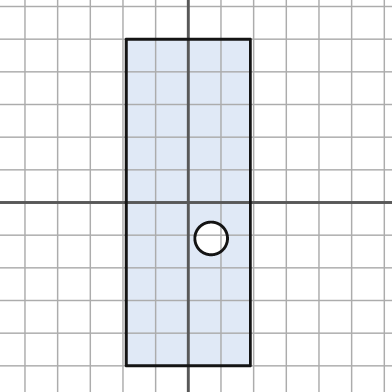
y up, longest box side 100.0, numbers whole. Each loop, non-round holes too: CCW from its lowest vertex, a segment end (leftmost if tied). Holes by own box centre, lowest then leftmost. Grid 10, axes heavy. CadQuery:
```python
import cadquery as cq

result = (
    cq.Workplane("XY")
    .moveTo(-19.0, -50.0)
    .lineTo(19.0, -50.0)
    .lineTo(19.0, 50.0)
    .lineTo(-19.0, 50.0)
    .close()
    .moveTo(7.0, -11.0)
    .circle(5.0)
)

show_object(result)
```